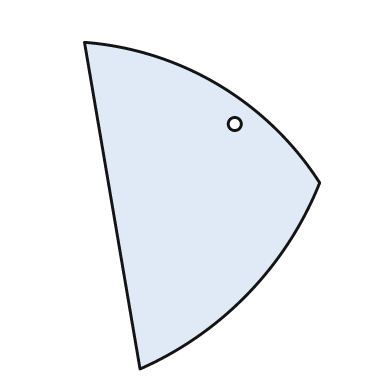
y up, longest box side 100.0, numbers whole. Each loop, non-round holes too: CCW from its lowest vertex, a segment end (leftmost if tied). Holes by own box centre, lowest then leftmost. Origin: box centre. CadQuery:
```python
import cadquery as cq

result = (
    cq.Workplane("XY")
    .moveTo(-19.0, -50.0)
    .threePointArc((14.0, -27.0), (36.0, 7.0))
    .threePointArc((5.0, 37.0), (-36.0, 50.0))
    .close()
    .moveTo(10.0, 25.0)
    .circle(2.0)
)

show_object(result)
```